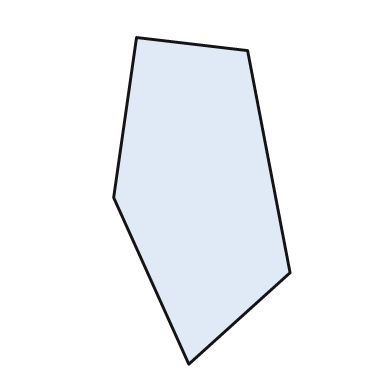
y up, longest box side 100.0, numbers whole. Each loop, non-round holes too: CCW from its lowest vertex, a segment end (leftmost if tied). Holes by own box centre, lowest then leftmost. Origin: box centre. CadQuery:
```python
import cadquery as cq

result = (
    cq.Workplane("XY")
    .moveTo(-4.0, -50.0)
    .lineTo(27.0, -22.0)
    .lineTo(14.0, 46.0)
    .lineTo(-20.0, 50.0)
    .lineTo(-27.0, 1.0)
    .close()
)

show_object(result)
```